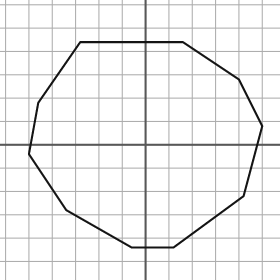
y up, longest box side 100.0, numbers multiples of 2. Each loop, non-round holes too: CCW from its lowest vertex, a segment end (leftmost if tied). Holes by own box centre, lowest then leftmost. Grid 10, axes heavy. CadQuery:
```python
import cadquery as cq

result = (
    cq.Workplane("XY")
    .moveTo(-6.0, -44.0)
    .lineTo(12.0, -44.0)
    .lineTo(42.0, -22.0)
    .lineTo(50.0, 8.0)
    .lineTo(40.0, 28.0)
    .lineTo(16.0, 44.0)
    .lineTo(-28.0, 44.0)
    .lineTo(-46.0, 18.0)
    .lineTo(-50.0, -4.0)
    .lineTo(-34.0, -28.0)
    .close()
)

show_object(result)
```